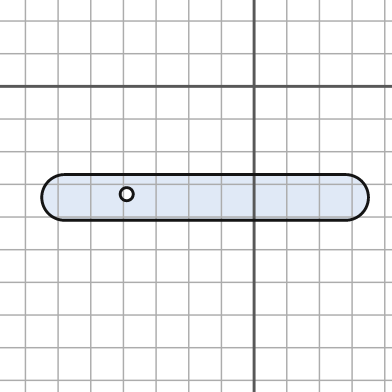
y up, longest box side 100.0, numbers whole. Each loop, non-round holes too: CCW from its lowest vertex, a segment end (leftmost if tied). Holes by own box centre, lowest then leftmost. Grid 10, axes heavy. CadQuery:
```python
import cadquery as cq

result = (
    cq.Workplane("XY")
    .moveTo(-58.0, -41.0)
    .lineTo(28.0, -41.0)
    .threePointArc((35.0, -34.0), (28.0, -27.0))
    .lineTo(-58.0, -27.0)
    .threePointArc((-65.0, -34.0), (-58.0, -41.0))
    .close()
    .moveTo(-39.0, -33.0)
    .circle(2.0)
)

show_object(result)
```